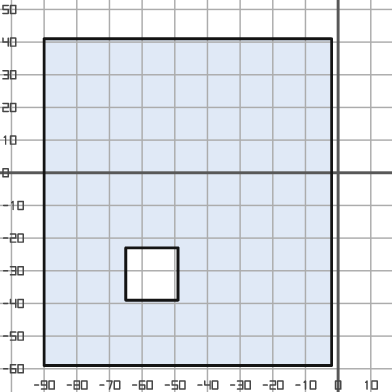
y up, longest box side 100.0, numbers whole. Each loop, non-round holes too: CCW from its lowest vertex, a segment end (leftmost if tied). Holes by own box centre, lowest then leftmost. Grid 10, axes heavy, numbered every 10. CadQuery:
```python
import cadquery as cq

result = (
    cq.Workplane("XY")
    .moveTo(-90.0, -59.0)
    .lineTo(-2.0, -59.0)
    .lineTo(-2.0, 41.0)
    .lineTo(-90.0, 41.0)
    .close()
    .moveTo(-65.0, -39.0)
    .lineTo(-49.0, -39.0)
    .lineTo(-49.0, -23.0)
    .lineTo(-65.0, -23.0)
    .close()
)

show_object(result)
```